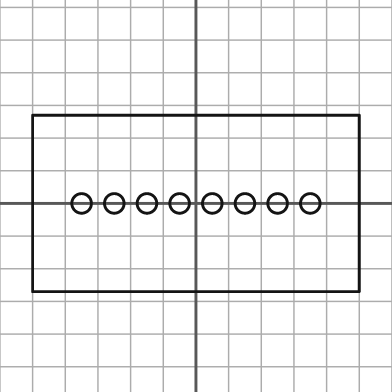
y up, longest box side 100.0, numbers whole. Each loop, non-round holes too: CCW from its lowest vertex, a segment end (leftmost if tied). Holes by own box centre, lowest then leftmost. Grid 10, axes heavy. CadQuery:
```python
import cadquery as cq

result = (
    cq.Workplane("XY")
    .moveTo(-50.0, -27.0)
    .lineTo(50.0, -27.0)
    .lineTo(50.0, 27.0)
    .lineTo(-50.0, 27.0)
    .close()
    .moveTo(-35.0, 0.0)
    .circle(3.0)
    .moveTo(-25.0, 0.0)
    .circle(3.0)
    .moveTo(-15.0, 0.0)
    .circle(3.0)
    .moveTo(-5.0, 0.0)
    .circle(3.0)
    .moveTo(5.0, 0.0)
    .circle(3.0)
    .moveTo(15.0, 0.0)
    .circle(3.0)
    .moveTo(25.0, 0.0)
    .circle(3.0)
    .moveTo(35.0, 0.0)
    .circle(3.0)
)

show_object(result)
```